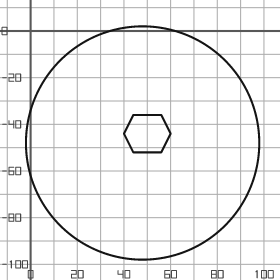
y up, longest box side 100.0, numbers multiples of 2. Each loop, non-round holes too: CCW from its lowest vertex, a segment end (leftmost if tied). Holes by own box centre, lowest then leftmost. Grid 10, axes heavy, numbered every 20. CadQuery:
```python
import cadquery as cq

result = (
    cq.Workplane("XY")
    .moveTo(48.0, -48.0)
    .circle(50.0)
    .moveTo(44.0, -52.0)
    .lineTo(56.0, -52.0)
    .lineTo(60.0, -44.0)
    .lineTo(56.0, -36.0)
    .lineTo(44.0, -36.0)
    .lineTo(40.0, -44.0)
    .close()
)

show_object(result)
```